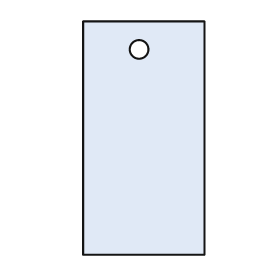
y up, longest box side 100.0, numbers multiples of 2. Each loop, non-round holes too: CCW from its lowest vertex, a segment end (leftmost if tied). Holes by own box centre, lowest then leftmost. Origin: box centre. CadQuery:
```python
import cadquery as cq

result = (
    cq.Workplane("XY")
    .moveTo(-26.0, -50.0)
    .lineTo(26.0, -50.0)
    .lineTo(26.0, 50.0)
    .lineTo(-26.0, 50.0)
    .close()
    .moveTo(-2.0, 38.0)
    .circle(4.0)
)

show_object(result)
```